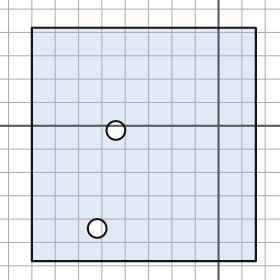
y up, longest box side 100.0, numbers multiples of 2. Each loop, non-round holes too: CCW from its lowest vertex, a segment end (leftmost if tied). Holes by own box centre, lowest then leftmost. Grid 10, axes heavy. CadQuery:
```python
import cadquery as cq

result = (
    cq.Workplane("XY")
    .moveTo(-80.0, -58.0)
    .lineTo(16.0, -58.0)
    .lineTo(16.0, 42.0)
    .lineTo(-80.0, 42.0)
    .close()
    .moveTo(-52.0, -44.0)
    .circle(4.0)
    .moveTo(-44.0, -2.0)
    .circle(4.0)
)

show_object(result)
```